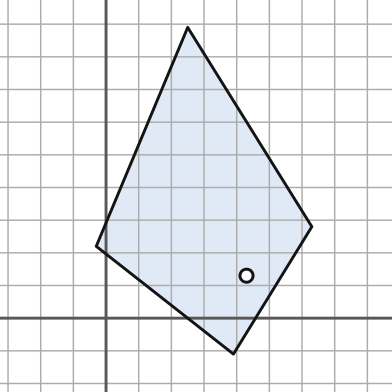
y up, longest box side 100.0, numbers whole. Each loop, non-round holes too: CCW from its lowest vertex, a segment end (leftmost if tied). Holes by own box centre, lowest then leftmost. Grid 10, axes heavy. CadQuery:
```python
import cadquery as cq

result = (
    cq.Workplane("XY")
    .moveTo(39.0, -11.0)
    .lineTo(63.0, 28.0)
    .lineTo(25.0, 89.0)
    .lineTo(-3.0, 22.0)
    .close()
    .moveTo(43.0, 13.0)
    .circle(2.0)
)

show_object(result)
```